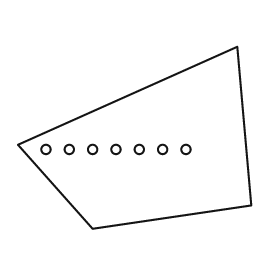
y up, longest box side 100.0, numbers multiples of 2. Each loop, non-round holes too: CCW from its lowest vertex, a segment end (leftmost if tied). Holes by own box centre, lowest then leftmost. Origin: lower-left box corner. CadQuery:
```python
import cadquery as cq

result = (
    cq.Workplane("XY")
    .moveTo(32.0, 0.0)
    .lineTo(100.0, 10.0)
    .lineTo(94.0, 78.0)
    .lineTo(0.0, 36.0)
    .close()
    .moveTo(12.0, 34.0)
    .circle(2.0)
    .moveTo(22.0, 34.0)
    .circle(2.0)
    .moveTo(32.0, 34.0)
    .circle(2.0)
    .moveTo(42.0, 34.0)
    .circle(2.0)
    .moveTo(52.0, 34.0)
    .circle(2.0)
    .moveTo(62.0, 34.0)
    .circle(2.0)
    .moveTo(72.0, 34.0)
    .circle(2.0)
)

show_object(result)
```